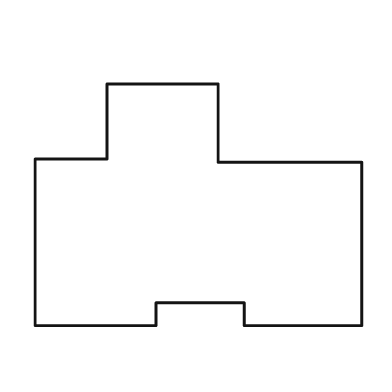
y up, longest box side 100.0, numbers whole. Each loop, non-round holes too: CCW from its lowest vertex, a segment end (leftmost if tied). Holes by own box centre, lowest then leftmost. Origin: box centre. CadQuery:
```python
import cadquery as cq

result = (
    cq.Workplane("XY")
    .moveTo(-50.0, -37.0)
    .lineTo(-13.0, -37.0)
    .lineTo(-13.0, -30.0)
    .lineTo(14.0, -30.0)
    .lineTo(14.0, -37.0)
    .lineTo(50.0, -37.0)
    .lineTo(50.0, 13.0)
    .lineTo(6.0, 13.0)
    .lineTo(6.0, 37.0)
    .lineTo(-28.0, 37.0)
    .lineTo(-28.0, 14.0)
    .lineTo(-50.0, 14.0)
    .close()
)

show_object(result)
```